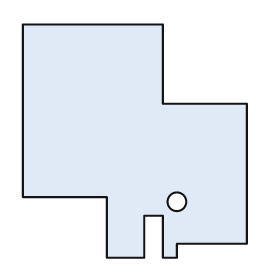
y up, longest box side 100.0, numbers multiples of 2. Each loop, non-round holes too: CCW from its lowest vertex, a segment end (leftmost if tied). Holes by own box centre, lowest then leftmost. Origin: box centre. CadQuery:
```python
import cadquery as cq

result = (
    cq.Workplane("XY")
    .moveTo(-12.0, -50.0)
    .lineTo(4.0, -50.0)
    .lineTo(4.0, -32.0)
    .lineTo(12.0, -32.0)
    .lineTo(12.0, -50.0)
    .lineTo(18.0, -50.0)
    .lineTo(18.0, -44.0)
    .lineTo(48.0, -44.0)
    .lineTo(48.0, 16.0)
    .lineTo(12.0, 16.0)
    .lineTo(12.0, 50.0)
    .lineTo(-48.0, 50.0)
    .lineTo(-48.0, -24.0)
    .lineTo(-12.0, -24.0)
    .close()
    .moveTo(18.0, -26.0)
    .circle(4.0)
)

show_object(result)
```